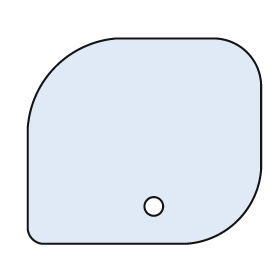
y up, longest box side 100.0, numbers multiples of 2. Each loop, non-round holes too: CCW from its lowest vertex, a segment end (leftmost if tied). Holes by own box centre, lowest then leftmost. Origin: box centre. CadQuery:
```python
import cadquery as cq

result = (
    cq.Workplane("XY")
    .moveTo(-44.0, -44.0)
    .lineTo(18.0, -44.0)
    .threePointArc((40.0, -34.0), (50.0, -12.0))
    .lineTo(50.0, 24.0)
    .threePointArc((44.0, 38.0), (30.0, 44.0))
    .lineTo(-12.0, 44.0)
    .threePointArc((-38.0, 32.0), (-50.0, 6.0))
    .lineTo(-50.0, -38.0)
    .threePointArc((-48.0, -42.0), (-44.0, -44.0))
    .close()
    .moveTo(4.0, -28.0)
    .circle(4.0)
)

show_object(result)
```